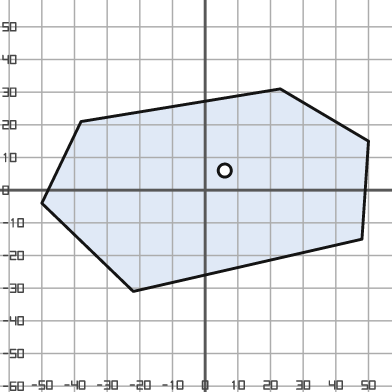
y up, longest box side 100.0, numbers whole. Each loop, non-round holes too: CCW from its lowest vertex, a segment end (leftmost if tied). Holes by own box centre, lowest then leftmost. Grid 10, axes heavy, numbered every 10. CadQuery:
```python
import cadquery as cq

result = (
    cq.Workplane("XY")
    .moveTo(-22.0, -31.0)
    .lineTo(48.0, -15.0)
    .lineTo(50.0, 15.0)
    .lineTo(23.0, 31.0)
    .lineTo(-38.0, 21.0)
    .lineTo(-50.0, -4.0)
    .close()
    .moveTo(6.0, 6.0)
    .circle(2.0)
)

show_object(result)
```